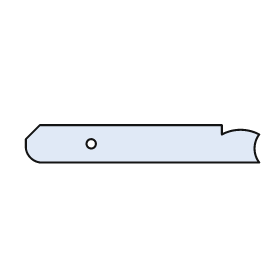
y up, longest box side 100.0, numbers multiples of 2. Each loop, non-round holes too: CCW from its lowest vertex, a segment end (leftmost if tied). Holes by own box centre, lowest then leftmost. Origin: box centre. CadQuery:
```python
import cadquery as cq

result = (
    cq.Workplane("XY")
    .moveTo(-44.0, -8.0)
    .lineTo(50.0, -8.0)
    .threePointArc((48.0, -2.0), (50.0, 4.0))
    .threePointArc((42.0, 6.0), (34.0, 4.0))
    .lineTo(34.0, 8.0)
    .lineTo(-44.0, 8.0)
    .lineTo(-50.0, 2.0)
    .lineTo(-50.0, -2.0)
    .threePointArc((-48.0, -6.0), (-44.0, -8.0))
    .close()
    .moveTo(-22.0, 0.0)
    .circle(2.0)
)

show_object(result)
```